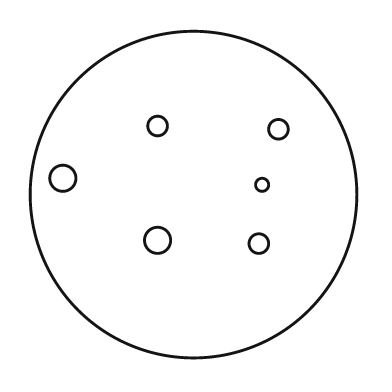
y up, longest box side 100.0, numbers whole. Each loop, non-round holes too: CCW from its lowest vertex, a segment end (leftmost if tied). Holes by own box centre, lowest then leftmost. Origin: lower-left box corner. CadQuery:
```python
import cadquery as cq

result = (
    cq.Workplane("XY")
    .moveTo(50.0, 50.0)
    .circle(50.0)
    .moveTo(70.0, 35.0)
    .circle(3.0)
    .moveTo(39.0, 36.0)
    .circle(4.0)
    .moveTo(71.0, 53.0)
    .circle(2.0)
    .moveTo(10.0, 55.0)
    .circle(4.0)
    .moveTo(76.0, 70.0)
    .circle(3.0)
    .moveTo(39.0, 71.0)
    .circle(3.0)
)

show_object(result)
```